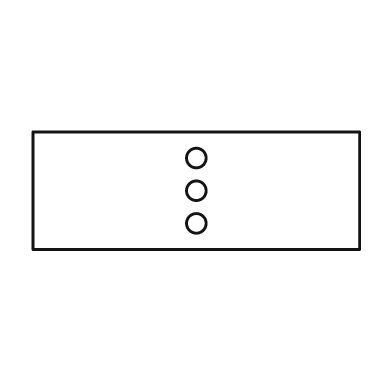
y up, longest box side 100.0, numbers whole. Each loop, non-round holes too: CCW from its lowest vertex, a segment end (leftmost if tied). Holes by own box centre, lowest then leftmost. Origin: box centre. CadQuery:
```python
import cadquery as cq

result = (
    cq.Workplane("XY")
    .moveTo(-50.0, -18.0)
    .lineTo(50.0, -18.0)
    .lineTo(50.0, 18.0)
    .lineTo(-50.0, 18.0)
    .close()
    .moveTo(0.0, -10.0)
    .circle(3.0)
    .moveTo(0.0, 0.0)
    .circle(3.0)
    .moveTo(0.0, 10.0)
    .circle(3.0)
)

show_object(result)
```